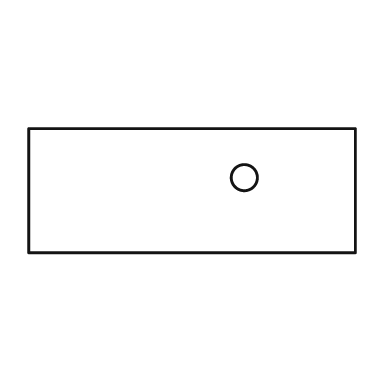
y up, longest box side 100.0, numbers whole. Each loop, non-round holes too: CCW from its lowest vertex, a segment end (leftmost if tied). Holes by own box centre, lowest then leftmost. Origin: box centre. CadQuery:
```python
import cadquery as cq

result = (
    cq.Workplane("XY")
    .moveTo(-50.0, -19.0)
    .lineTo(50.0, -19.0)
    .lineTo(50.0, 19.0)
    .lineTo(-50.0, 19.0)
    .close()
    .moveTo(16.0, 4.0)
    .circle(4.0)
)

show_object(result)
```